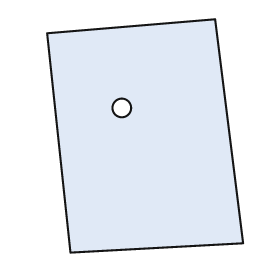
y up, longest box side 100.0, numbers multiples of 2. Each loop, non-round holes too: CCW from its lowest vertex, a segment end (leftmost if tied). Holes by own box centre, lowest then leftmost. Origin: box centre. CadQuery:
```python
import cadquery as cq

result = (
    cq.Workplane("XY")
    .moveTo(-32.0, -50.0)
    .lineTo(42.0, -46.0)
    .lineTo(30.0, 50.0)
    .lineTo(-42.0, 44.0)
    .close()
    .moveTo(-10.0, 12.0)
    .circle(4.0)
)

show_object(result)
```